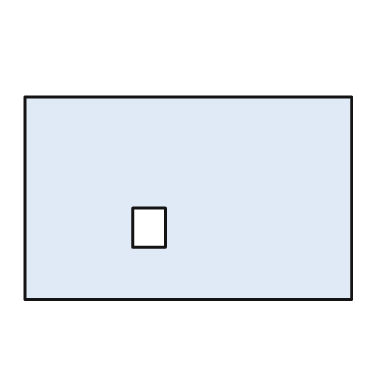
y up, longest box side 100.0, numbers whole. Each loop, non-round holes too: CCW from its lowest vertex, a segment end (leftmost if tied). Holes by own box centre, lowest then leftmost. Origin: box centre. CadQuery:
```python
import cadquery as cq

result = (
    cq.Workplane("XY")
    .moveTo(-50.0, -31.0)
    .lineTo(50.0, -31.0)
    .lineTo(50.0, 31.0)
    .lineTo(-50.0, 31.0)
    .close()
    .moveTo(-17.0, -15.0)
    .lineTo(-7.0, -15.0)
    .lineTo(-7.0, -3.0)
    .lineTo(-17.0, -3.0)
    .close()
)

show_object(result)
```